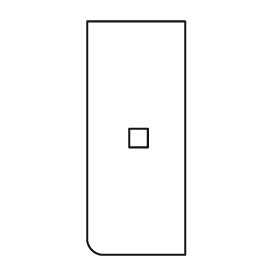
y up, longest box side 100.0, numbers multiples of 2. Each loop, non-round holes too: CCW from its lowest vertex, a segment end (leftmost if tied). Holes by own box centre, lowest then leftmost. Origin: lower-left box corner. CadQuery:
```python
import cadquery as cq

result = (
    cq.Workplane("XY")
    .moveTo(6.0, 0.0)
    .lineTo(42.0, 0.0)
    .lineTo(42.0, 100.0)
    .lineTo(0.0, 100.0)
    .lineTo(0.0, 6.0)
    .threePointArc((2.0, 2.0), (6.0, 0.0))
    .close()
    .moveTo(18.0, 46.0)
    .lineTo(26.0, 46.0)
    .lineTo(26.0, 54.0)
    .lineTo(18.0, 54.0)
    .close()
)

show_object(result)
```